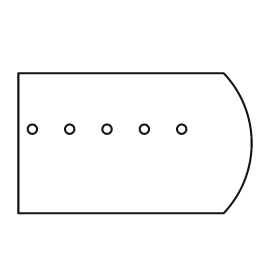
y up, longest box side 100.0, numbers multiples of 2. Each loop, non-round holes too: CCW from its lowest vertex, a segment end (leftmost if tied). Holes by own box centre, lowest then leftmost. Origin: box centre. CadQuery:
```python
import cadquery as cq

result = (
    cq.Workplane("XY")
    .moveTo(-50.0, -30.0)
    .lineTo(38.0, -30.0)
    .threePointArc((50.0, 0.0), (38.0, 30.0))
    .lineTo(-50.0, 30.0)
    .close()
    .moveTo(-44.0, 6.0)
    .circle(2.0)
    .moveTo(-28.0, 6.0)
    .circle(2.0)
    .moveTo(-12.0, 6.0)
    .circle(2.0)
    .moveTo(4.0, 6.0)
    .circle(2.0)
    .moveTo(20.0, 6.0)
    .circle(2.0)
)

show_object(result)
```